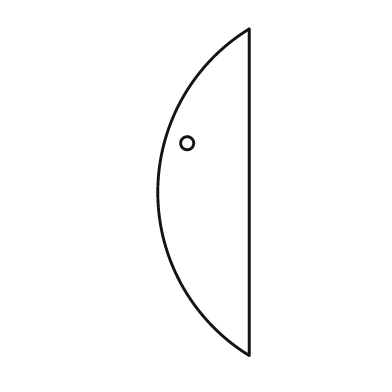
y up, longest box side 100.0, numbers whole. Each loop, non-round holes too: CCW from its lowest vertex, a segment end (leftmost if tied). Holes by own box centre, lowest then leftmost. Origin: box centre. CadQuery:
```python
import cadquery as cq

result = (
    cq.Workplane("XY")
    .moveTo(14.0, -50.0)
    .lineTo(14.0, 50.0)
    .threePointArc((-14.0, 0.0), (14.0, -50.0))
    .close()
    .moveTo(-5.0, 15.0)
    .circle(2.0)
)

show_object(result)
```